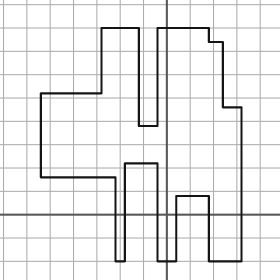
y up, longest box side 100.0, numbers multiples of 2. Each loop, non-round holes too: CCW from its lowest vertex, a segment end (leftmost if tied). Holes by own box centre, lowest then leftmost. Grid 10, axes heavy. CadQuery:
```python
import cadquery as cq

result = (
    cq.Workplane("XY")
    .moveTo(-22.0, -20.0)
    .lineTo(-18.0, -20.0)
    .lineTo(-18.0, 22.0)
    .lineTo(-4.0, 22.0)
    .lineTo(-4.0, -20.0)
    .lineTo(4.0, -20.0)
    .lineTo(4.0, 8.0)
    .lineTo(18.0, 8.0)
    .lineTo(18.0, -20.0)
    .lineTo(32.0, -20.0)
    .lineTo(32.0, 46.0)
    .lineTo(24.0, 46.0)
    .lineTo(24.0, 74.0)
    .lineTo(18.0, 74.0)
    .lineTo(18.0, 80.0)
    .lineTo(-4.0, 80.0)
    .lineTo(-4.0, 38.0)
    .lineTo(-12.0, 38.0)
    .lineTo(-12.0, 80.0)
    .lineTo(-28.0, 80.0)
    .lineTo(-28.0, 52.0)
    .lineTo(-54.0, 52.0)
    .lineTo(-54.0, 16.0)
    .lineTo(-22.0, 16.0)
    .close()
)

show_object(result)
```